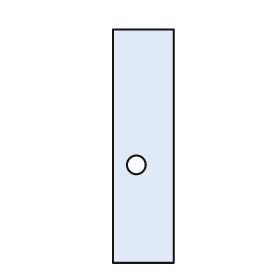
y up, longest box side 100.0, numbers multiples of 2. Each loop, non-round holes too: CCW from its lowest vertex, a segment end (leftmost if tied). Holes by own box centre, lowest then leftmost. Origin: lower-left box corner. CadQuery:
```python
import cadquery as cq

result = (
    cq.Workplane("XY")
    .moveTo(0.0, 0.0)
    .lineTo(26.0, 0.0)
    .lineTo(26.0, 100.0)
    .lineTo(0.0, 100.0)
    .close()
    .moveTo(10.0, 42.0)
    .circle(4.0)
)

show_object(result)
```